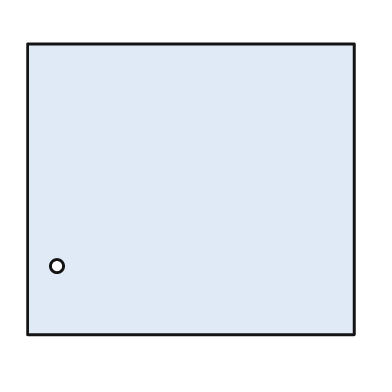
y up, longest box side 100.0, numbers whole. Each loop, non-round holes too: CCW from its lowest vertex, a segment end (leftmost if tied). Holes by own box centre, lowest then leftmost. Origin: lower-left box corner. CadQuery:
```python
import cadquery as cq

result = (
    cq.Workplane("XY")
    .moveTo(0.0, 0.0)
    .lineTo(100.0, 0.0)
    .lineTo(100.0, 89.0)
    .lineTo(0.0, 89.0)
    .close()
    .moveTo(9.0, 21.0)
    .circle(2.0)
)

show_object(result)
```